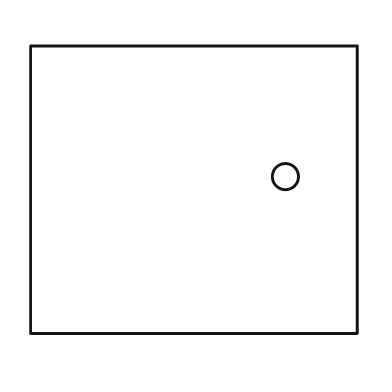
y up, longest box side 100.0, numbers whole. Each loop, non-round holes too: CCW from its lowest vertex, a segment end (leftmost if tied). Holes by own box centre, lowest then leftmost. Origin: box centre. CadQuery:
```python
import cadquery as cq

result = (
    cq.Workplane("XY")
    .moveTo(-50.0, -44.0)
    .lineTo(50.0, -44.0)
    .lineTo(50.0, 44.0)
    .lineTo(-50.0, 44.0)
    .close()
    .moveTo(28.0, 4.0)
    .circle(4.0)
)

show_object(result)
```